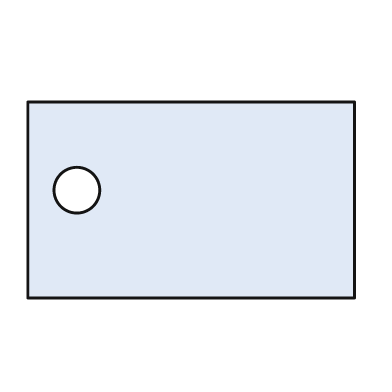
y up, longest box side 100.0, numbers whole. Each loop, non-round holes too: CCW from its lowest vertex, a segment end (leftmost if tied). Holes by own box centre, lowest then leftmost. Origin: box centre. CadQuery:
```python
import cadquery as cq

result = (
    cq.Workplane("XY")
    .moveTo(-50.0, -30.0)
    .lineTo(50.0, -30.0)
    .lineTo(50.0, 30.0)
    .lineTo(-50.0, 30.0)
    .close()
    .moveTo(-35.0, 3.0)
    .circle(7.0)
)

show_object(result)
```